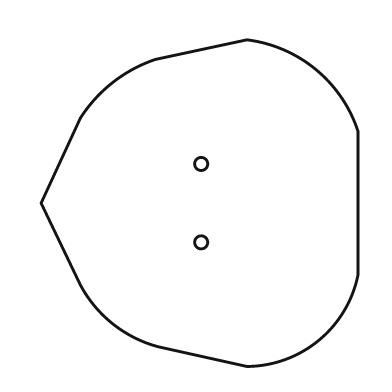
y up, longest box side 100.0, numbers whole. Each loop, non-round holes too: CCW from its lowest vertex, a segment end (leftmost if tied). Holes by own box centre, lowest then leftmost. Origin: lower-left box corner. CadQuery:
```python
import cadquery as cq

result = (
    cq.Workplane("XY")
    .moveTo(63.0, 0.0)
    .threePointArc((85.0, 8.0), (97.0, 28.0))
    .lineTo(97.0, 72.0)
    .threePointArc((84.0, 91.0), (63.0, 100.0))
    .lineTo(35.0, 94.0)
    .threePointArc((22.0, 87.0), (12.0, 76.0))
    .lineTo(0.0, 50.0)
    .lineTo(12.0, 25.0)
    .threePointArc((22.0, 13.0), (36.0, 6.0))
    .close()
    .moveTo(49.0, 38.0)
    .circle(2.0)
    .moveTo(49.0, 62.0)
    .circle(2.0)
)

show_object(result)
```